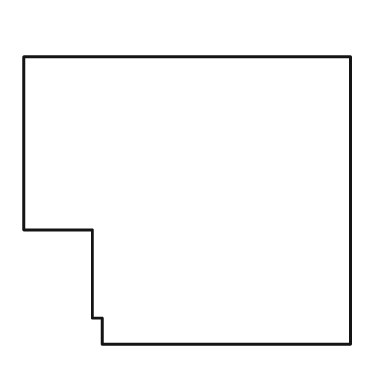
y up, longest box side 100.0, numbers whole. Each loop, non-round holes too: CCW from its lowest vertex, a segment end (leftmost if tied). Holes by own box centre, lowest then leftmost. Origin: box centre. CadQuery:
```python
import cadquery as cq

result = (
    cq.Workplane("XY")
    .moveTo(-26.0, -44.0)
    .lineTo(50.0, -44.0)
    .lineTo(50.0, 44.0)
    .lineTo(-50.0, 44.0)
    .lineTo(-50.0, -9.0)
    .lineTo(-29.0, -9.0)
    .lineTo(-29.0, -36.0)
    .lineTo(-26.0, -36.0)
    .close()
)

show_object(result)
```